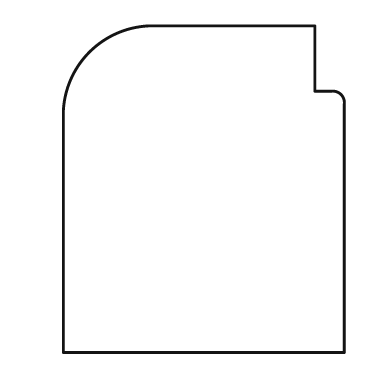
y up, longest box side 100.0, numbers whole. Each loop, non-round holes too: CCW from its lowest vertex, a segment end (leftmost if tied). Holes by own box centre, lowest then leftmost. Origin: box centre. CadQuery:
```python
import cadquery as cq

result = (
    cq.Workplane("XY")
    .moveTo(-43.0, -50.0)
    .lineTo(43.0, -50.0)
    .lineTo(43.0, 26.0)
    .threePointArc((42.0, 29.0), (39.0, 30.0))
    .lineTo(34.0, 30.0)
    .lineTo(34.0, 50.0)
    .lineTo(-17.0, 50.0)
    .threePointArc((-35.0, 42.0), (-43.0, 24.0))
    .close()
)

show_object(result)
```